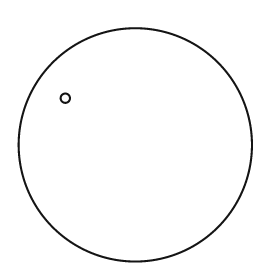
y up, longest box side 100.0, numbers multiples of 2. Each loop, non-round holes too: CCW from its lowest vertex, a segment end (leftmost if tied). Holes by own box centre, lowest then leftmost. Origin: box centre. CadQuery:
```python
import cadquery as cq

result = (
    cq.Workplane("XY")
    .moveTo(0.0, 0.0)
    .circle(50.0)
    .moveTo(-30.0, 20.0)
    .circle(2.0)
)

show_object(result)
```